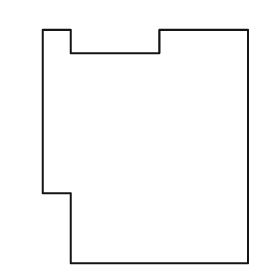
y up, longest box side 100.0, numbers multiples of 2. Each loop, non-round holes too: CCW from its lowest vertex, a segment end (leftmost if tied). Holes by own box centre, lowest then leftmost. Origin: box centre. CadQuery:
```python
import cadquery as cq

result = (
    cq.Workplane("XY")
    .moveTo(-32.0, -50.0)
    .lineTo(44.0, -50.0)
    .lineTo(44.0, 50.0)
    .lineTo(6.0, 50.0)
    .lineTo(6.0, 40.0)
    .lineTo(-32.0, 40.0)
    .lineTo(-32.0, 50.0)
    .lineTo(-44.0, 50.0)
    .lineTo(-44.0, -20.0)
    .lineTo(-32.0, -20.0)
    .close()
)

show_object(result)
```